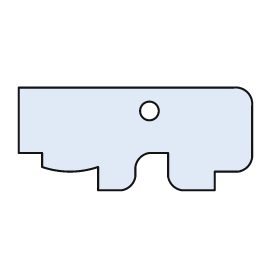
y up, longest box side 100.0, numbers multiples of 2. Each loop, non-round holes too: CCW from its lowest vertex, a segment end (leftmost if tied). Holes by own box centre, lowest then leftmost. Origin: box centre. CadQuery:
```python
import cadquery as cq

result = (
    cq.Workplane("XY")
    .moveTo(-16.0, -22.0)
    .lineTo(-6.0, -22.0)
    .threePointArc((-2.0, -20.0), (0.0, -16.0))
    .lineTo(0.0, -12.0)
    .threePointArc((2.0, -8.0), (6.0, -6.0))
    .lineTo(14.0, -6.0)
    .lineTo(14.0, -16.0)
    .threePointArc((16.0, -20.0), (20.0, -22.0))
    .lineTo(34.0, -22.0)
    .lineTo(34.0, -14.0)
    .lineTo(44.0, -14.0)
    .threePointArc((48.0, -12.0), (50.0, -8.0))
    .lineTo(50.0, 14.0)
    .threePointArc((48.0, 20.0), (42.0, 22.0))
    .lineTo(-50.0, 22.0)
    .lineTo(-50.0, -6.0)
    .lineTo(-40.0, -6.0)
    .lineTo(-40.0, -12.0)
    .threePointArc((-28.0, -14.0), (-16.0, -12.0))
    .close()
    .moveTo(6.0, 12.0)
    .circle(4.0)
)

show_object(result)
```